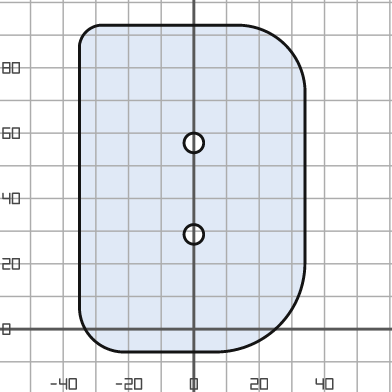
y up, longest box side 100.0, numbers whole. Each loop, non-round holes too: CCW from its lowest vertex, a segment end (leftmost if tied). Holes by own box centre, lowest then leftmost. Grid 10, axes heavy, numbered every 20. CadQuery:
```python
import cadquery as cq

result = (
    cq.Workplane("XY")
    .moveTo(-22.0, -7.0)
    .lineTo(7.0, -7.0)
    .threePointArc((26.0, 1.0), (34.0, 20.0))
    .lineTo(34.0, 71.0)
    .threePointArc((28.0, 87.0), (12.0, 93.0))
    .lineTo(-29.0, 93.0)
    .threePointArc((-33.0, 91.0), (-35.0, 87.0))
    .lineTo(-35.0, 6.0)
    .threePointArc((-31.0, -3.0), (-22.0, -7.0))
    .close()
    .moveTo(0.0, 29.0)
    .circle(3.0)
    .moveTo(0.0, 57.0)
    .circle(3.0)
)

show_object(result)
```